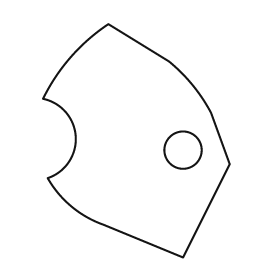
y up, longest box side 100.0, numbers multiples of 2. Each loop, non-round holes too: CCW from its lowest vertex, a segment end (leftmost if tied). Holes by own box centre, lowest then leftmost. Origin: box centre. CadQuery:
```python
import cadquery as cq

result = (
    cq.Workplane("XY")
    .moveTo(20.0, -50.0)
    .lineTo(40.0, -10.0)
    .lineTo(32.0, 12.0)
    .threePointArc((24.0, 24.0), (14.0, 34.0))
    .lineTo(-12.0, 50.0)
    .threePointArc((-28.0, 36.0), (-40.0, 18.0))
    .threePointArc((-26.0, 2.0), (-38.0, -16.0))
    .threePointArc((-28.0, -28.0), (-14.0, -36.0))
    .close()
    .moveTo(20.0, -4.0)
    .circle(8.0)
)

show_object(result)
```